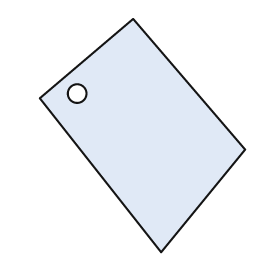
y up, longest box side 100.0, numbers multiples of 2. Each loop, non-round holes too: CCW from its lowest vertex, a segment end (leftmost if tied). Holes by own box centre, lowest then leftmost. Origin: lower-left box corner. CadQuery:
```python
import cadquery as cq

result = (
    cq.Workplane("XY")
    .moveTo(52.0, 0.0)
    .lineTo(88.0, 44.0)
    .lineTo(40.0, 100.0)
    .lineTo(0.0, 66.0)
    .close()
    .moveTo(16.0, 68.0)
    .circle(4.0)
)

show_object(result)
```